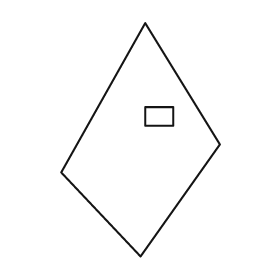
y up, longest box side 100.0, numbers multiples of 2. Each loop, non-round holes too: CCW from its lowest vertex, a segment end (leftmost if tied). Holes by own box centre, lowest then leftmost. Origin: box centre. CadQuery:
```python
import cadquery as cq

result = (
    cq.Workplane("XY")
    .moveTo(0.0, -50.0)
    .lineTo(34.0, -2.0)
    .lineTo(2.0, 50.0)
    .lineTo(-34.0, -14.0)
    .close()
    .moveTo(2.0, 6.0)
    .lineTo(14.0, 6.0)
    .lineTo(14.0, 14.0)
    .lineTo(2.0, 14.0)
    .close()
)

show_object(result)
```